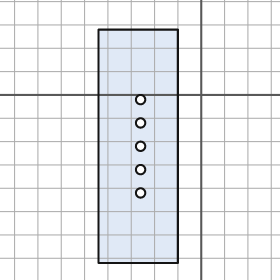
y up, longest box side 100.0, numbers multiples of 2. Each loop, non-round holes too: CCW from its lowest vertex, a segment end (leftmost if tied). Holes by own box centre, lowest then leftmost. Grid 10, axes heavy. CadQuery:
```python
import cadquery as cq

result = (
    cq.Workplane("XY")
    .moveTo(-44.0, -72.0)
    .lineTo(-10.0, -72.0)
    .lineTo(-10.0, 28.0)
    .lineTo(-44.0, 28.0)
    .close()
    .moveTo(-26.0, -42.0)
    .circle(2.0)
    .moveTo(-26.0, -32.0)
    .circle(2.0)
    .moveTo(-26.0, -22.0)
    .circle(2.0)
    .moveTo(-26.0, -12.0)
    .circle(2.0)
    .moveTo(-26.0, -2.0)
    .circle(2.0)
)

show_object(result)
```